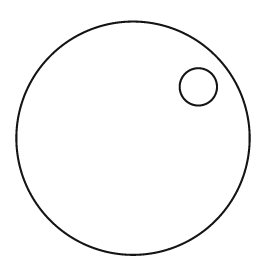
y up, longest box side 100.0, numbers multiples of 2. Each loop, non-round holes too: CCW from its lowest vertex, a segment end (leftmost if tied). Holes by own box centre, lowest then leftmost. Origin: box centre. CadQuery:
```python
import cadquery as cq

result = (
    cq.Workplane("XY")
    .moveTo(0.0, 0.0)
    .circle(50.0)
    .moveTo(28.0, 22.0)
    .circle(8.0)
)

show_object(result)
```